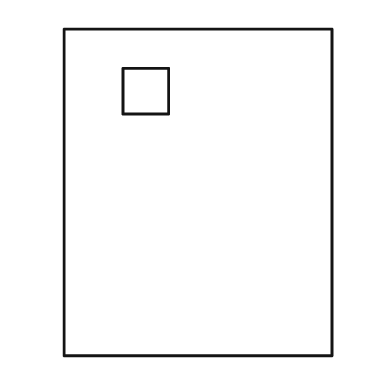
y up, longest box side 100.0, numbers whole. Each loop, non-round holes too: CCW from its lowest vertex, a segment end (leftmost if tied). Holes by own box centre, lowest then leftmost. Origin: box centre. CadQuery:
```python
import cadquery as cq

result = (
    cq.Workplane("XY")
    .moveTo(-41.0, -50.0)
    .lineTo(41.0, -50.0)
    .lineTo(41.0, 50.0)
    .lineTo(-41.0, 50.0)
    .close()
    .moveTo(-23.0, 24.0)
    .lineTo(-9.0, 24.0)
    .lineTo(-9.0, 38.0)
    .lineTo(-23.0, 38.0)
    .close()
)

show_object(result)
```